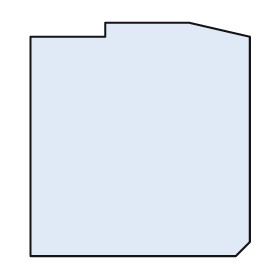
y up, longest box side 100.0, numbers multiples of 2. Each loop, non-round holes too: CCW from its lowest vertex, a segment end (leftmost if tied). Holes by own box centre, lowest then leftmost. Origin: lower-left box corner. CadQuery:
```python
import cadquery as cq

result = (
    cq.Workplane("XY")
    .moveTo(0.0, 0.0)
    .lineTo(88.0, 0.0)
    .lineTo(94.0, 6.0)
    .lineTo(94.0, 94.0)
    .lineTo(68.0, 100.0)
    .lineTo(32.0, 100.0)
    .lineTo(32.0, 94.0)
    .lineTo(0.0, 94.0)
    .close()
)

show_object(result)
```